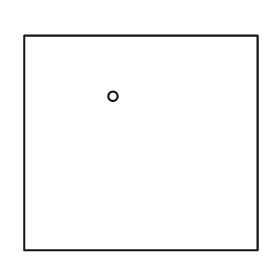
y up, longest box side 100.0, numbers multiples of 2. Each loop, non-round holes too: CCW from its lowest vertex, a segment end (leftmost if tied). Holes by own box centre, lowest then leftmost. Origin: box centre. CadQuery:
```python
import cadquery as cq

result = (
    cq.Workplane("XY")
    .moveTo(-50.0, -46.0)
    .lineTo(50.0, -46.0)
    .lineTo(50.0, 46.0)
    .lineTo(-50.0, 46.0)
    .close()
    .moveTo(-12.0, 20.0)
    .circle(2.0)
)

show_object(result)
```